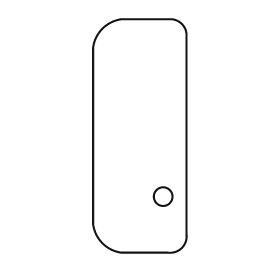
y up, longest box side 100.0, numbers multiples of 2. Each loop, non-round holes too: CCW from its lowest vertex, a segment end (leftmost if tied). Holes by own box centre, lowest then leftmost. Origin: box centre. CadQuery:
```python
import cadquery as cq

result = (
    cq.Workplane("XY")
    .moveTo(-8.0, -50.0)
    .lineTo(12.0, -50.0)
    .threePointArc((18.0, -48.0), (20.0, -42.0))
    .lineTo(20.0, 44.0)
    .threePointArc((18.0, 48.0), (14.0, 50.0))
    .lineTo(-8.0, 50.0)
    .threePointArc((-16.0, 46.0), (-20.0, 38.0))
    .lineTo(-20.0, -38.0)
    .threePointArc((-16.0, -46.0), (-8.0, -50.0))
    .close()
    .moveTo(10.0, -26.0)
    .circle(4.0)
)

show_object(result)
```